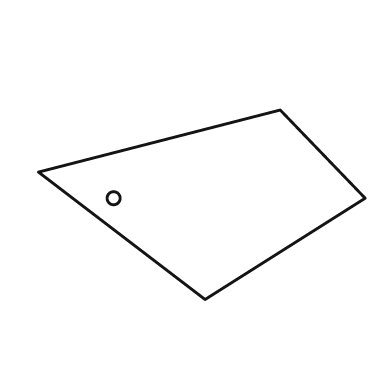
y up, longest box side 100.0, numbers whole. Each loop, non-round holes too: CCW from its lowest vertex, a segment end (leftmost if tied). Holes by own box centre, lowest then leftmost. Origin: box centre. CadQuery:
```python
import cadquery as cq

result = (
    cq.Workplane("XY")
    .moveTo(1.0, -29.0)
    .lineTo(50.0, 2.0)
    .lineTo(24.0, 29.0)
    .lineTo(-50.0, 10.0)
    .close()
    .moveTo(-27.0, 2.0)
    .circle(2.0)
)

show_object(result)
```